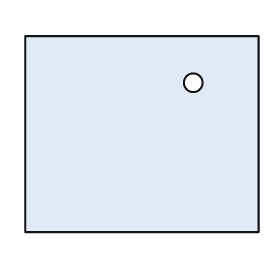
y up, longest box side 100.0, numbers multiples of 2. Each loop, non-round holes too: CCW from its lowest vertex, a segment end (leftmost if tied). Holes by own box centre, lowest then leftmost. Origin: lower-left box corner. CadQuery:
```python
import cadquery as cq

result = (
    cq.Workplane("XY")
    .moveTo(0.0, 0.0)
    .lineTo(100.0, 0.0)
    .lineTo(100.0, 84.0)
    .lineTo(0.0, 84.0)
    .close()
    .moveTo(72.0, 64.0)
    .circle(4.0)
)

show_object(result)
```